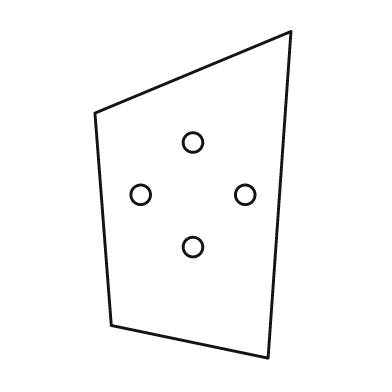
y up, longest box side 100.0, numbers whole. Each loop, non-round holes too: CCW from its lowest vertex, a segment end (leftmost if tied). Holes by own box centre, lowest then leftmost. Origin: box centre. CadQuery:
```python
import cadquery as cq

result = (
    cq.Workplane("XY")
    .moveTo(23.0, -50.0)
    .lineTo(30.0, 50.0)
    .lineTo(-30.0, 25.0)
    .lineTo(-25.0, -40.0)
    .close()
    .moveTo(0.0, -16.0)
    .circle(3.0)
    .moveTo(-16.0, 0.0)
    .circle(3.0)
    .moveTo(16.0, 0.0)
    .circle(3.0)
    .moveTo(0.0, 16.0)
    .circle(3.0)
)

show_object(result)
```